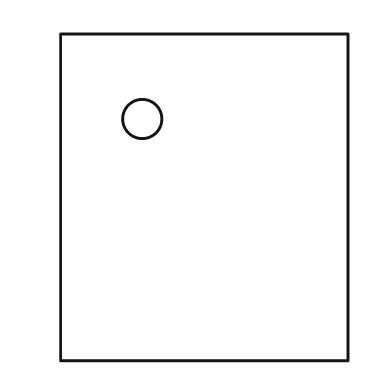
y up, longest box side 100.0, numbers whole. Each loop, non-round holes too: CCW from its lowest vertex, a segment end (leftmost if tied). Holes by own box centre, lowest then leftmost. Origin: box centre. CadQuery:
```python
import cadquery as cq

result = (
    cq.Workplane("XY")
    .moveTo(-44.0, -50.0)
    .lineTo(44.0, -50.0)
    .lineTo(44.0, 50.0)
    .lineTo(-44.0, 50.0)
    .close()
    .moveTo(-19.0, 24.0)
    .circle(6.0)
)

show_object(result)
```